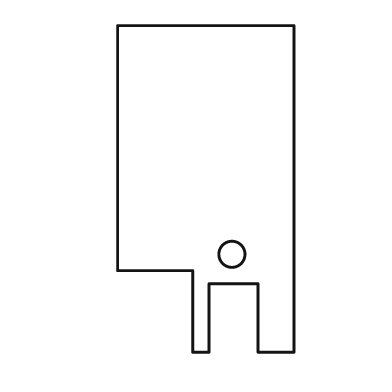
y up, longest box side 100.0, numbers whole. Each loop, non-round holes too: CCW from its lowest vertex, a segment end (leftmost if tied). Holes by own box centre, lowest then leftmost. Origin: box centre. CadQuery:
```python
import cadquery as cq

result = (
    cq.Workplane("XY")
    .moveTo(-4.0, -50.0)
    .lineTo(1.0, -50.0)
    .lineTo(1.0, -29.0)
    .lineTo(16.0, -29.0)
    .lineTo(16.0, -50.0)
    .lineTo(27.0, -50.0)
    .lineTo(27.0, 50.0)
    .lineTo(-27.0, 50.0)
    .lineTo(-27.0, -25.0)
    .lineTo(-4.0, -25.0)
    .close()
    .moveTo(8.0, -20.0)
    .circle(4.0)
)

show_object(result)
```